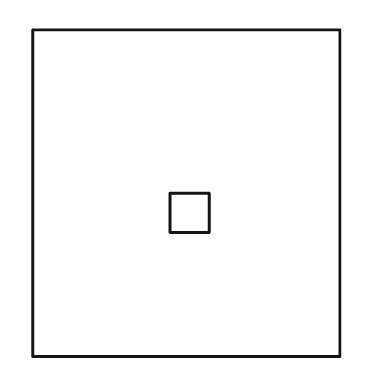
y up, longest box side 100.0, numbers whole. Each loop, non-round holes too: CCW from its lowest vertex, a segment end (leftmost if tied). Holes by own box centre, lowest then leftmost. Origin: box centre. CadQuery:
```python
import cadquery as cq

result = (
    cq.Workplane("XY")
    .moveTo(-47.0, -50.0)
    .lineTo(47.0, -50.0)
    .lineTo(47.0, 50.0)
    .lineTo(-47.0, 50.0)
    .close()
    .moveTo(-5.0, -12.0)
    .lineTo(7.0, -12.0)
    .lineTo(7.0, 0.0)
    .lineTo(-5.0, 0.0)
    .close()
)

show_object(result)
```